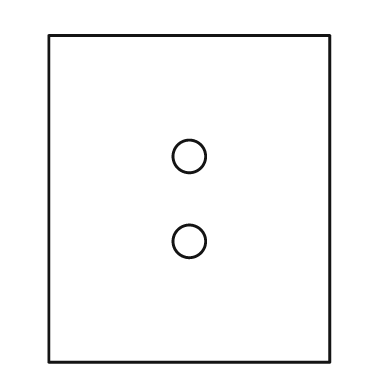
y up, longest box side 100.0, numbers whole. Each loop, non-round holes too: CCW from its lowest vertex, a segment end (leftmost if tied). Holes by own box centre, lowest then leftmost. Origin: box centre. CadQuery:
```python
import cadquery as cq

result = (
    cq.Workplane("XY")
    .moveTo(-43.0, -50.0)
    .lineTo(43.0, -50.0)
    .lineTo(43.0, 50.0)
    .lineTo(-43.0, 50.0)
    .close()
    .moveTo(0.0, -13.0)
    .circle(5.0)
    .moveTo(0.0, 13.0)
    .circle(5.0)
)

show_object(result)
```